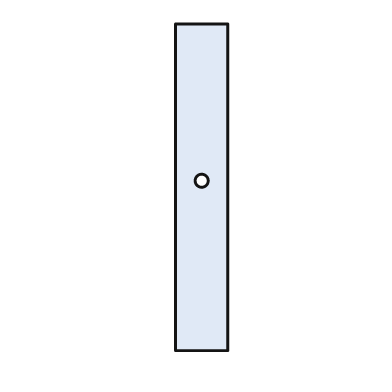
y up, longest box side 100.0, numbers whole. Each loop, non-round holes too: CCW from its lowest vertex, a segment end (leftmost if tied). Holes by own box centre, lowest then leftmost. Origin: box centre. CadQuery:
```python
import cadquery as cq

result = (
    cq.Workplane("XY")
    .moveTo(-8.0, -50.0)
    .lineTo(8.0, -50.0)
    .lineTo(8.0, 50.0)
    .lineTo(-8.0, 50.0)
    .close()
    .moveTo(0.0, 2.0)
    .circle(2.0)
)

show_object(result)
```